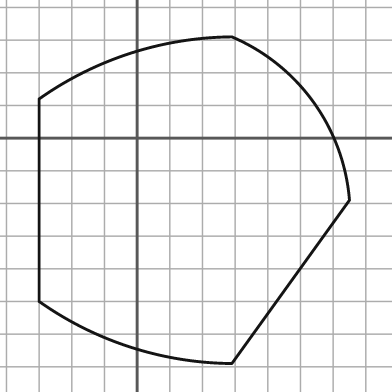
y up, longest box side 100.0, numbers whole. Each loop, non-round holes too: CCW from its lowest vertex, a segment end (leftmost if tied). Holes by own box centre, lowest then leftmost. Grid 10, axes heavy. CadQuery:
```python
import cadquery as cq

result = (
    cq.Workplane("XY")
    .moveTo(29.0, -69.0)
    .lineTo(65.0, -19.0)
    .threePointArc((54.0, 11.0), (29.0, 31.0))
    .threePointArc((-2.0, 26.0), (-30.0, 12.0))
    .lineTo(-30.0, -50.0)
    .threePointArc((-2.0, -64.0), (29.0, -69.0))
    .close()
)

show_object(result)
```